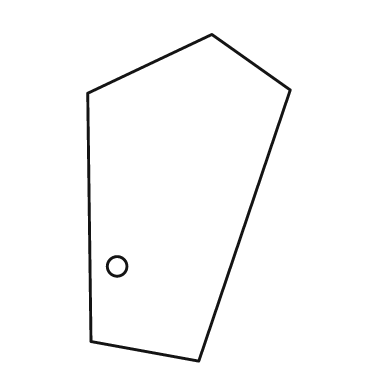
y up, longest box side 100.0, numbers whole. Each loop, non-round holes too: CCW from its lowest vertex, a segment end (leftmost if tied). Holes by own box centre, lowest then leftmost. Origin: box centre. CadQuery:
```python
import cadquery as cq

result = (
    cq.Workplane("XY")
    .moveTo(3.0, -50.0)
    .lineTo(31.0, 33.0)
    .lineTo(7.0, 50.0)
    .lineTo(-31.0, 32.0)
    .lineTo(-30.0, -44.0)
    .close()
    .moveTo(-22.0, -21.0)
    .circle(3.0)
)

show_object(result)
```